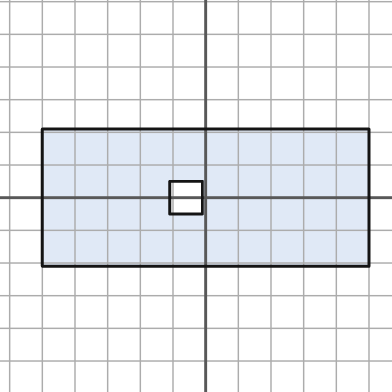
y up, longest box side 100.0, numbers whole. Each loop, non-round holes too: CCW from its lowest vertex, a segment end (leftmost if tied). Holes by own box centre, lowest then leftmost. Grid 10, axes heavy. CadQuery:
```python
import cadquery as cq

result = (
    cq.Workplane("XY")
    .moveTo(-50.0, -21.0)
    .lineTo(50.0, -21.0)
    .lineTo(50.0, 21.0)
    .lineTo(-50.0, 21.0)
    .close()
    .moveTo(-11.0, -5.0)
    .lineTo(-1.0, -5.0)
    .lineTo(-1.0, 5.0)
    .lineTo(-11.0, 5.0)
    .close()
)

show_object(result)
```